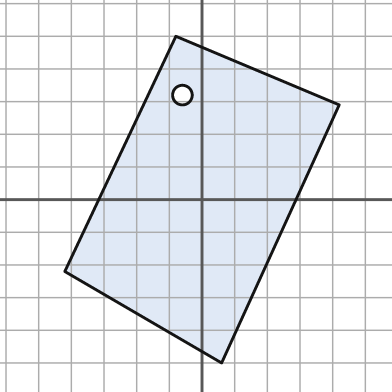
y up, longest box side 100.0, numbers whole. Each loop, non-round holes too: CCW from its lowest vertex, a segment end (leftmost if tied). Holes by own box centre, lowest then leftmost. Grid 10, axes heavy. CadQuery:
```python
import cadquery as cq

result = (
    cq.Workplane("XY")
    .moveTo(6.0, -50.0)
    .lineTo(42.0, 29.0)
    .lineTo(-8.0, 50.0)
    .lineTo(-42.0, -22.0)
    .close()
    .moveTo(-6.0, 32.0)
    .circle(3.0)
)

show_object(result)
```